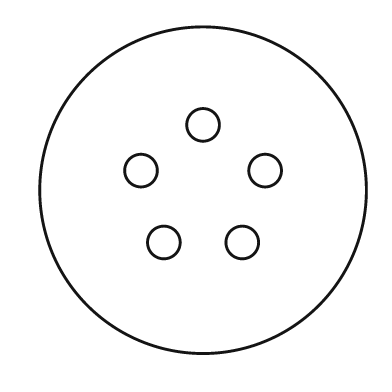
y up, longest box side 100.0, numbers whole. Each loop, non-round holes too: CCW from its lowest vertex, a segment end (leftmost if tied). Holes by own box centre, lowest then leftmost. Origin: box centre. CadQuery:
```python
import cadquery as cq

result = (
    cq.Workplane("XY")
    .moveTo(0.0, 0.0)
    .circle(50.0)
    .moveTo(-12.0, -16.0)
    .circle(5.0)
    .moveTo(12.0, -16.0)
    .circle(5.0)
    .moveTo(-19.0, 6.0)
    .circle(5.0)
    .moveTo(19.0, 6.0)
    .circle(5.0)
    .moveTo(0.0, 20.0)
    .circle(5.0)
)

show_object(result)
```